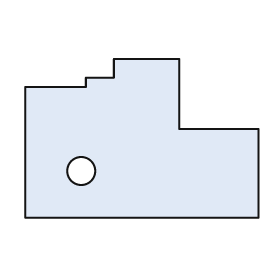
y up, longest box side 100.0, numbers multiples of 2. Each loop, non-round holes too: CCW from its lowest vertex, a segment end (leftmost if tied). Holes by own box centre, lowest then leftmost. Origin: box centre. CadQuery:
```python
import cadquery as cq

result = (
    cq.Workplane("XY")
    .moveTo(-50.0, -34.0)
    .lineTo(50.0, -34.0)
    .lineTo(50.0, 4.0)
    .lineTo(16.0, 4.0)
    .lineTo(16.0, 34.0)
    .lineTo(-12.0, 34.0)
    .lineTo(-12.0, 26.0)
    .lineTo(-24.0, 26.0)
    .lineTo(-24.0, 22.0)
    .lineTo(-50.0, 22.0)
    .close()
    .moveTo(-26.0, -14.0)
    .circle(6.0)
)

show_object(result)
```